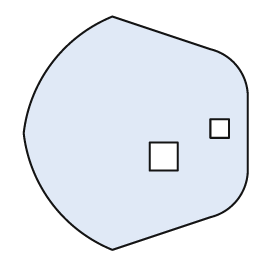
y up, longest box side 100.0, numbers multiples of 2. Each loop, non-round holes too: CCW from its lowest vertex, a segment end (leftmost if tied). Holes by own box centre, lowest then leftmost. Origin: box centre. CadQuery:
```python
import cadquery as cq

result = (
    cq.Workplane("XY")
    .moveTo(-10.0, -50.0)
    .lineTo(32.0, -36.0)
    .threePointArc((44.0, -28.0), (48.0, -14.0))
    .lineTo(48.0, 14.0)
    .threePointArc((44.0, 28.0), (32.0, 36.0))
    .lineTo(-10.0, 50.0)
    .threePointArc((-36.0, 30.0), (-48.0, 0.0))
    .threePointArc((-36.0, -30.0), (-10.0, -50.0))
    .close()
    .moveTo(6.0, -16.0)
    .lineTo(18.0, -16.0)
    .lineTo(18.0, -4.0)
    .lineTo(6.0, -4.0)
    .close()
    .moveTo(32.0, -2.0)
    .lineTo(40.0, -2.0)
    .lineTo(40.0, 6.0)
    .lineTo(32.0, 6.0)
    .close()
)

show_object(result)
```